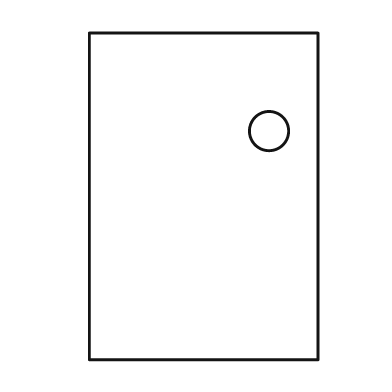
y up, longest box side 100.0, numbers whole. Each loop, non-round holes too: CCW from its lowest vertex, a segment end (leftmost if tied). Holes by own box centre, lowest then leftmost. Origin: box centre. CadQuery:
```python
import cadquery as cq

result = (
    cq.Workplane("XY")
    .moveTo(-35.0, -50.0)
    .lineTo(35.0, -50.0)
    .lineTo(35.0, 50.0)
    .lineTo(-35.0, 50.0)
    .close()
    .moveTo(20.0, 20.0)
    .circle(6.0)
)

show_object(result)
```